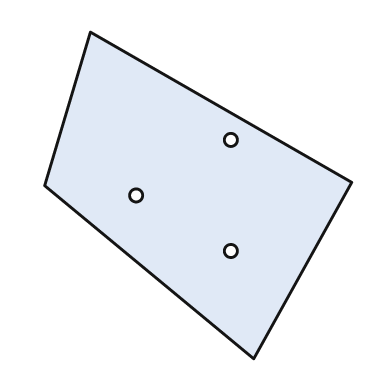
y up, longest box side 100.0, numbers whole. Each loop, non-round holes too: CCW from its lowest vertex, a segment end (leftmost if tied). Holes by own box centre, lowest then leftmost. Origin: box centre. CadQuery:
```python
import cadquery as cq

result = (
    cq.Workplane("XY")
    .moveTo(17.0, -50.0)
    .lineTo(47.0, 4.0)
    .lineTo(-33.0, 50.0)
    .lineTo(-47.0, 3.0)
    .close()
    .moveTo(10.0, -17.0)
    .circle(2.0)
    .moveTo(-19.0, 0.0)
    .circle(2.0)
    .moveTo(10.0, 17.0)
    .circle(2.0)
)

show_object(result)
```